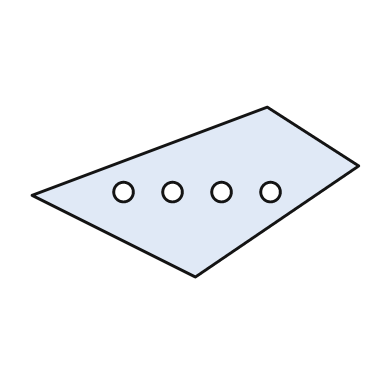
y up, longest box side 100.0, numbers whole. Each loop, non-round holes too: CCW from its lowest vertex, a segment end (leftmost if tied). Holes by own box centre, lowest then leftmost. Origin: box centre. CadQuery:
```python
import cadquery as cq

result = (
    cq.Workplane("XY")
    .moveTo(0.0, -26.0)
    .lineTo(50.0, 8.0)
    .lineTo(22.0, 26.0)
    .lineTo(-50.0, -1.0)
    .close()
    .moveTo(-22.0, 0.0)
    .circle(3.0)
    .moveTo(-7.0, 0.0)
    .circle(3.0)
    .moveTo(8.0, 0.0)
    .circle(3.0)
    .moveTo(23.0, 0.0)
    .circle(3.0)
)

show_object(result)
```